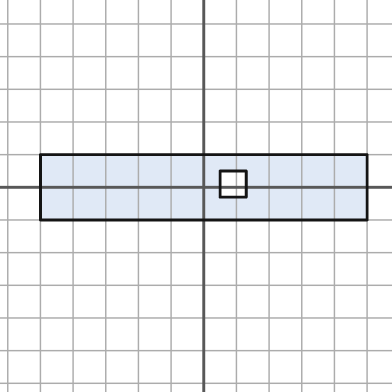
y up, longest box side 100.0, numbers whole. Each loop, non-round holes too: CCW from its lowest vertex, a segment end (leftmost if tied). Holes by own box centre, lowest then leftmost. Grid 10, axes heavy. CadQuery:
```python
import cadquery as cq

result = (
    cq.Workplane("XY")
    .moveTo(-50.0, -10.0)
    .lineTo(50.0, -10.0)
    .lineTo(50.0, 10.0)
    .lineTo(-50.0, 10.0)
    .close()
    .moveTo(5.0, -3.0)
    .lineTo(13.0, -3.0)
    .lineTo(13.0, 5.0)
    .lineTo(5.0, 5.0)
    .close()
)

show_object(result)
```